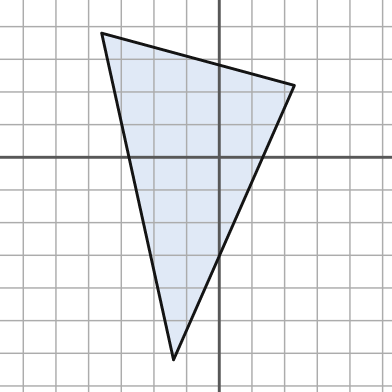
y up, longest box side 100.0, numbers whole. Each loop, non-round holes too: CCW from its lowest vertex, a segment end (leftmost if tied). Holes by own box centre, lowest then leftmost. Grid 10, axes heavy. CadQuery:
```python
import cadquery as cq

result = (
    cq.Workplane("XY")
    .moveTo(-14.0, -62.0)
    .lineTo(23.0, 22.0)
    .lineTo(-36.0, 38.0)
    .close()
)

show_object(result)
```